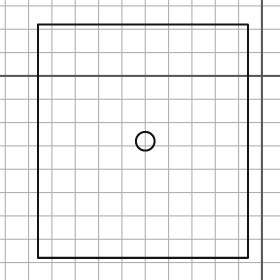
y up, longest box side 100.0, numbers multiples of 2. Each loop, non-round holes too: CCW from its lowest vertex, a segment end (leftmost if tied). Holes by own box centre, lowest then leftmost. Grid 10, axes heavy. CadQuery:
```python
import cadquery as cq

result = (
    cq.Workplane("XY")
    .moveTo(-96.0, -78.0)
    .lineTo(-6.0, -78.0)
    .lineTo(-6.0, 22.0)
    .lineTo(-96.0, 22.0)
    .close()
    .moveTo(-50.0, -28.0)
    .circle(4.0)
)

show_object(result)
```